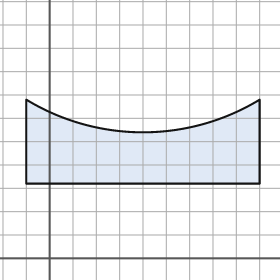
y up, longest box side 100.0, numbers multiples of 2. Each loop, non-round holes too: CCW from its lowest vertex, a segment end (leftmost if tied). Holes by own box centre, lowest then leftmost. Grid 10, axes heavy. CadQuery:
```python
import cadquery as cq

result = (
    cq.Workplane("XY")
    .moveTo(-10.0, 32.0)
    .lineTo(90.0, 32.0)
    .lineTo(90.0, 68.0)
    .threePointArc((40.0, 54.0), (-10.0, 68.0))
    .close()
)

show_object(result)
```